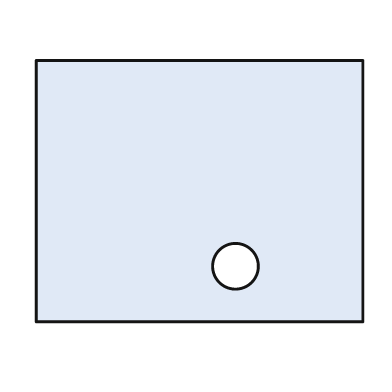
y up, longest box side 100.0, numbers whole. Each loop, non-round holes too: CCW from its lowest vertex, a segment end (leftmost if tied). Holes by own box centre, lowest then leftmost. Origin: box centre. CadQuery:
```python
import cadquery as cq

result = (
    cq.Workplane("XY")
    .moveTo(-50.0, -40.0)
    .lineTo(50.0, -40.0)
    .lineTo(50.0, 40.0)
    .lineTo(-50.0, 40.0)
    .close()
    .moveTo(11.0, -23.0)
    .circle(7.0)
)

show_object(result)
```